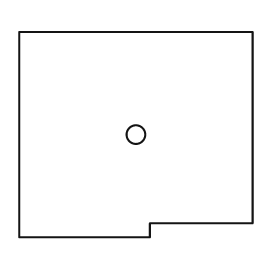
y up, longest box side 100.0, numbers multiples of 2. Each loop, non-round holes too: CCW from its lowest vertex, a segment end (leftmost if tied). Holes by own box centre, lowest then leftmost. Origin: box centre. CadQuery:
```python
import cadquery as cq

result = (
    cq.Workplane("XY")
    .moveTo(-50.0, -44.0)
    .lineTo(6.0, -44.0)
    .lineTo(6.0, -38.0)
    .lineTo(50.0, -38.0)
    .lineTo(50.0, 44.0)
    .lineTo(-50.0, 44.0)
    .close()
    .moveTo(0.0, 0.0)
    .circle(4.0)
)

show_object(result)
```